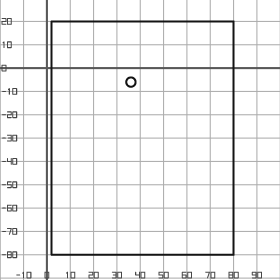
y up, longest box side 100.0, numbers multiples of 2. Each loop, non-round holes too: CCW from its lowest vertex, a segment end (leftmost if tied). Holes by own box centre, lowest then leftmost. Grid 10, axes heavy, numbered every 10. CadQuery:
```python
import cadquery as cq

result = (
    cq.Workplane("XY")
    .moveTo(2.0, -80.0)
    .lineTo(80.0, -80.0)
    .lineTo(80.0, 20.0)
    .lineTo(2.0, 20.0)
    .close()
    .moveTo(36.0, -6.0)
    .circle(2.0)
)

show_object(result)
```